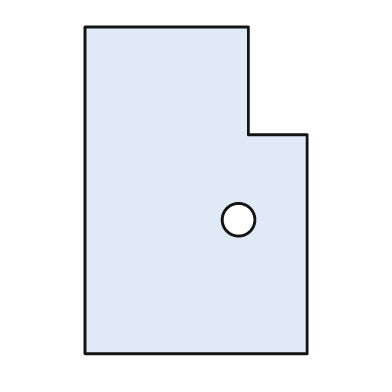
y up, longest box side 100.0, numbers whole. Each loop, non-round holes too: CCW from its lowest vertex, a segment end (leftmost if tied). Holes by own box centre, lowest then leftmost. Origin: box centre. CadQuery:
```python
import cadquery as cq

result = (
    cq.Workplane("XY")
    .moveTo(-34.0, -50.0)
    .lineTo(34.0, -50.0)
    .lineTo(34.0, 17.0)
    .lineTo(16.0, 17.0)
    .lineTo(16.0, 50.0)
    .lineTo(-34.0, 50.0)
    .close()
    .moveTo(13.0, -9.0)
    .circle(5.0)
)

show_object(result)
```